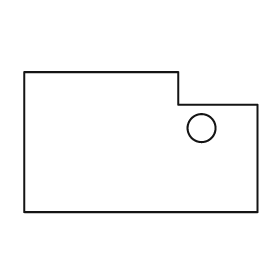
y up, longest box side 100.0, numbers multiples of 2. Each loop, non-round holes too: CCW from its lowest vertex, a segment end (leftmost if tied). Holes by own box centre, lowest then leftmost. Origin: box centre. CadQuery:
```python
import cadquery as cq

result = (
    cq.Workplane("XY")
    .moveTo(-50.0, -30.0)
    .lineTo(50.0, -30.0)
    .lineTo(50.0, 16.0)
    .lineTo(16.0, 16.0)
    .lineTo(16.0, 30.0)
    .lineTo(-50.0, 30.0)
    .close()
    .moveTo(26.0, 6.0)
    .circle(6.0)
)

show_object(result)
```